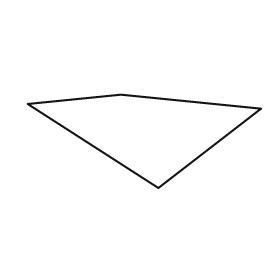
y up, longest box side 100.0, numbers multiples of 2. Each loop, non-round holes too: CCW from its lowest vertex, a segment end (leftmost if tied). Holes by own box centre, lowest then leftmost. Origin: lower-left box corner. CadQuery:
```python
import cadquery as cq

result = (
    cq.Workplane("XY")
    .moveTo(56.0, 0.0)
    .lineTo(100.0, 34.0)
    .lineTo(40.0, 40.0)
    .lineTo(0.0, 36.0)
    .close()
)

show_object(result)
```